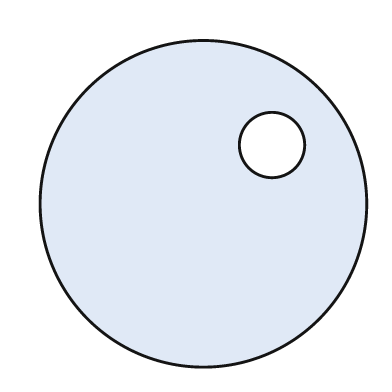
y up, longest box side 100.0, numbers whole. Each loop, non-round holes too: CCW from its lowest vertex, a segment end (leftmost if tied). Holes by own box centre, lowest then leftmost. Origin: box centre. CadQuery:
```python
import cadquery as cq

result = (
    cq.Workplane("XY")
    .moveTo(0.0, 0.0)
    .circle(50.0)
    .moveTo(21.0, 18.0)
    .circle(10.0)
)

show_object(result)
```